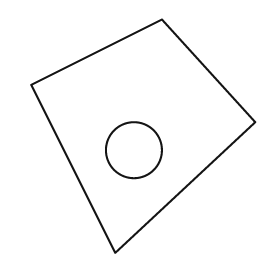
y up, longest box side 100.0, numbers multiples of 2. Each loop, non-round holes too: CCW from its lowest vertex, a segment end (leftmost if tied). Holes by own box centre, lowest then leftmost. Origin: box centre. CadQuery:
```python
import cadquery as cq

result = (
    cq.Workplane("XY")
    .moveTo(-12.0, -50.0)
    .lineTo(48.0, 6.0)
    .lineTo(8.0, 50.0)
    .lineTo(-48.0, 22.0)
    .close()
    .moveTo(-4.0, -6.0)
    .circle(12.0)
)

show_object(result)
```